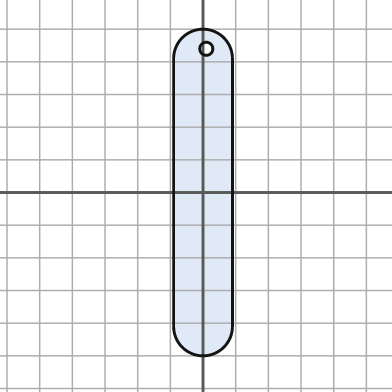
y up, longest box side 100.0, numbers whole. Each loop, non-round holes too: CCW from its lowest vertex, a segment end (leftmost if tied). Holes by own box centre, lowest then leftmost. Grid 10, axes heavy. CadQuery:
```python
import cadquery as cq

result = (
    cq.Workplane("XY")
    .moveTo(-9.0, -41.0)
    .threePointArc((0.0, -50.0), (9.0, -41.0))
    .lineTo(9.0, 41.0)
    .threePointArc((0.0, 50.0), (-9.0, 41.0))
    .close()
    .moveTo(1.0, 44.0)
    .circle(2.0)
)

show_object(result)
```